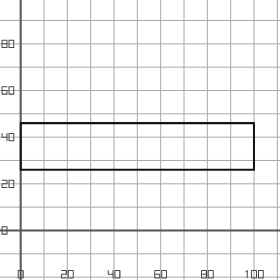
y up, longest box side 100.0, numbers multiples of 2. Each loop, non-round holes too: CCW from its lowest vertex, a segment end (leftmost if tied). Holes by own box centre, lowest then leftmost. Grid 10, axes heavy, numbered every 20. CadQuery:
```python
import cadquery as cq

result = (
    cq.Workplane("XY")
    .moveTo(0.0, 26.0)
    .lineTo(100.0, 26.0)
    .lineTo(100.0, 46.0)
    .lineTo(0.0, 46.0)
    .close()
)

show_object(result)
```